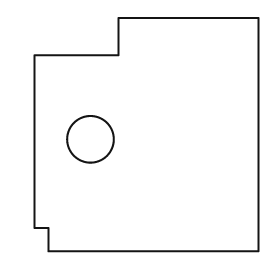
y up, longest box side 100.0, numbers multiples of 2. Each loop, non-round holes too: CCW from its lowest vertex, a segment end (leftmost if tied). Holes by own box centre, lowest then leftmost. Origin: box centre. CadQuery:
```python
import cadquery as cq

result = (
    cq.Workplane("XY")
    .moveTo(-42.0, -50.0)
    .lineTo(48.0, -50.0)
    .lineTo(48.0, 50.0)
    .lineTo(-12.0, 50.0)
    .lineTo(-12.0, 34.0)
    .lineTo(-48.0, 34.0)
    .lineTo(-48.0, -40.0)
    .lineTo(-42.0, -40.0)
    .close()
    .moveTo(-24.0, -2.0)
    .circle(10.0)
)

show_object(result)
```